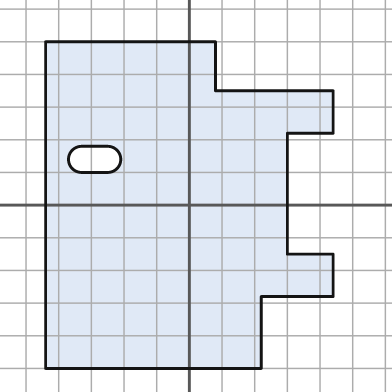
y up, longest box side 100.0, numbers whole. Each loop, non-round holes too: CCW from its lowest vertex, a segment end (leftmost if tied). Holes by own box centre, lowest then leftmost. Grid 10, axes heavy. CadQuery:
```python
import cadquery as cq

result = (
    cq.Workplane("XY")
    .moveTo(-44.0, -50.0)
    .lineTo(22.0, -50.0)
    .lineTo(22.0, -28.0)
    .lineTo(44.0, -28.0)
    .lineTo(44.0, -15.0)
    .lineTo(30.0, -15.0)
    .lineTo(30.0, 22.0)
    .lineTo(44.0, 22.0)
    .lineTo(44.0, 35.0)
    .lineTo(8.0, 35.0)
    .lineTo(8.0, 50.0)
    .lineTo(-44.0, 50.0)
    .close()
    .moveTo(-33.0, 10.0)
    .lineTo(-25.0, 10.0)
    .threePointArc((-21.0, 14.0), (-25.0, 18.0))
    .lineTo(-33.0, 18.0)
    .threePointArc((-37.0, 14.0), (-33.0, 10.0))
    .close()
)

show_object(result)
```